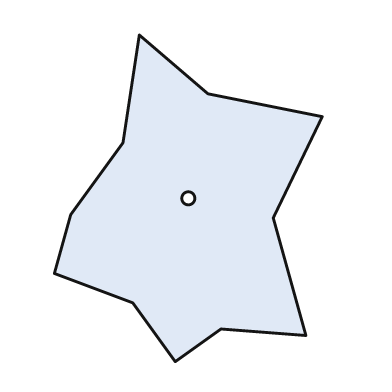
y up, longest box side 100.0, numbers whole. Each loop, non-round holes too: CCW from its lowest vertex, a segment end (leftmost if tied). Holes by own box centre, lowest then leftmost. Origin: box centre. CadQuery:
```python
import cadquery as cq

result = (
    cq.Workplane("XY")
    .moveTo(-4.0, -50.0)
    .lineTo(10.0, -40.0)
    .lineTo(36.0, -42.0)
    .lineTo(26.0, -6.0)
    .lineTo(41.0, 25.0)
    .lineTo(6.0, 32.0)
    .lineTo(-15.0, 50.0)
    .lineTo(-20.0, 17.0)
    .lineTo(-36.0, -5.0)
    .lineTo(-41.0, -23.0)
    .lineTo(-17.0, -32.0)
    .close()
    .moveTo(0.0, 0.0)
    .circle(2.0)
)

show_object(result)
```